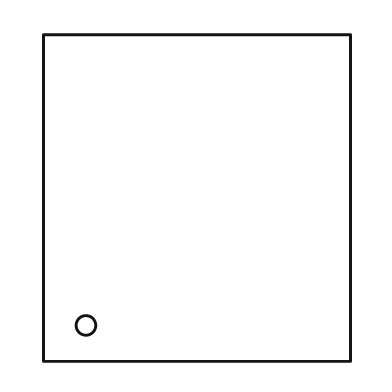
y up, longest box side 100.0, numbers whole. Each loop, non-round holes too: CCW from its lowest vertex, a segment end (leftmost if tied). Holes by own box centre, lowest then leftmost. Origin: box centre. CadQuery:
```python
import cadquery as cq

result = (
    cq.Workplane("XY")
    .moveTo(-47.0, -50.0)
    .lineTo(47.0, -50.0)
    .lineTo(47.0, 50.0)
    .lineTo(-47.0, 50.0)
    .close()
    .moveTo(-34.0, -39.0)
    .circle(3.0)
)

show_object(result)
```